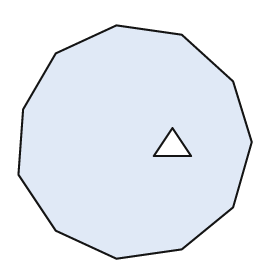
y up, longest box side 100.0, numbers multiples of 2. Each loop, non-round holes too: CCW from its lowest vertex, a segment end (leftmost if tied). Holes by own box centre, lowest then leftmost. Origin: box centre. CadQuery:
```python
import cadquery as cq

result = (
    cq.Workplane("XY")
    .moveTo(-8.0, -50.0)
    .lineTo(20.0, -46.0)
    .lineTo(42.0, -28.0)
    .lineTo(50.0, 0.0)
    .lineTo(42.0, 26.0)
    .lineTo(20.0, 46.0)
    .lineTo(-8.0, 50.0)
    .lineTo(-34.0, 38.0)
    .lineTo(-48.0, 14.0)
    .lineTo(-50.0, -14.0)
    .lineTo(-34.0, -38.0)
    .close()
    .moveTo(8.0, -6.0)
    .lineTo(24.0, -6.0)
    .lineTo(16.0, 6.0)
    .close()
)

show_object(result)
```